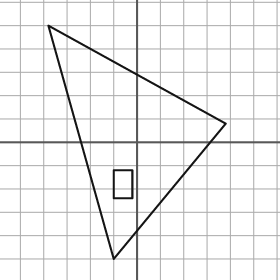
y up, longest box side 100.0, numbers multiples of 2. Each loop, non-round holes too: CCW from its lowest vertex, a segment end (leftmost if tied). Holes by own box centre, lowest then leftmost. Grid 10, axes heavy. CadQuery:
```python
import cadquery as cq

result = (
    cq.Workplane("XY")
    .moveTo(-10.0, -50.0)
    .lineTo(38.0, 8.0)
    .lineTo(-38.0, 50.0)
    .close()
    .moveTo(-10.0, -24.0)
    .lineTo(-2.0, -24.0)
    .lineTo(-2.0, -12.0)
    .lineTo(-10.0, -12.0)
    .close()
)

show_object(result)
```